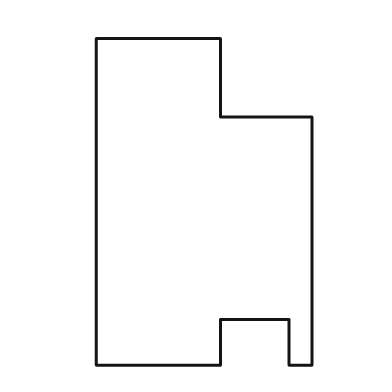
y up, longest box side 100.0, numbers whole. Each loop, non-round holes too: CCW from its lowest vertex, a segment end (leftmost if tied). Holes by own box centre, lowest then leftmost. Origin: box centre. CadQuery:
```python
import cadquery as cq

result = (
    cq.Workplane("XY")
    .moveTo(-33.0, -50.0)
    .lineTo(5.0, -50.0)
    .lineTo(5.0, -36.0)
    .lineTo(26.0, -36.0)
    .lineTo(26.0, -50.0)
    .lineTo(33.0, -50.0)
    .lineTo(33.0, 26.0)
    .lineTo(5.0, 26.0)
    .lineTo(5.0, 50.0)
    .lineTo(-33.0, 50.0)
    .close()
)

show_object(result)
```